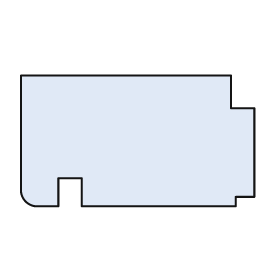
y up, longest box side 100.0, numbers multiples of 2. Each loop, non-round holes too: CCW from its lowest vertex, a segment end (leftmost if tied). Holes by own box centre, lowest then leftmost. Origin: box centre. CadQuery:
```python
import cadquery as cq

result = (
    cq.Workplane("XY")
    .moveTo(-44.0, -28.0)
    .lineTo(-34.0, -28.0)
    .lineTo(-34.0, -16.0)
    .lineTo(-24.0, -16.0)
    .lineTo(-24.0, -28.0)
    .lineTo(42.0, -28.0)
    .lineTo(42.0, -24.0)
    .lineTo(50.0, -24.0)
    .lineTo(50.0, 14.0)
    .lineTo(40.0, 14.0)
    .lineTo(40.0, 28.0)
    .lineTo(-50.0, 28.0)
    .lineTo(-50.0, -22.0)
    .threePointArc((-48.0, -26.0), (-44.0, -28.0))
    .close()
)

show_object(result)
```